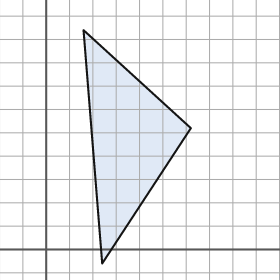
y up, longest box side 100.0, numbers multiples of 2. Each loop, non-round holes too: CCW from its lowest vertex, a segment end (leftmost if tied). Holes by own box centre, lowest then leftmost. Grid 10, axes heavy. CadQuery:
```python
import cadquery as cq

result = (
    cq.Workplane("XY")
    .moveTo(24.0, -6.0)
    .lineTo(62.0, 52.0)
    .lineTo(16.0, 94.0)
    .close()
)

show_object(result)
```